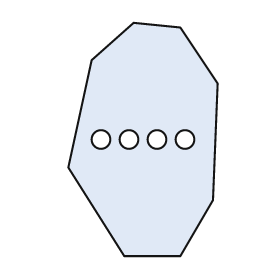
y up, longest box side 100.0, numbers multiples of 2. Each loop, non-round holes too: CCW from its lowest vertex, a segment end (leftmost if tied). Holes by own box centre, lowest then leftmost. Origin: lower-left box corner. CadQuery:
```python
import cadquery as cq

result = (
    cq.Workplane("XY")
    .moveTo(24.0, 0.0)
    .lineTo(48.0, 0.0)
    .lineTo(62.0, 24.0)
    .lineTo(64.0, 74.0)
    .lineTo(48.0, 98.0)
    .lineTo(28.0, 100.0)
    .lineTo(10.0, 84.0)
    .lineTo(0.0, 38.0)
    .close()
    .moveTo(14.0, 50.0)
    .circle(4.0)
    .moveTo(26.0, 50.0)
    .circle(4.0)
    .moveTo(38.0, 50.0)
    .circle(4.0)
    .moveTo(50.0, 50.0)
    .circle(4.0)
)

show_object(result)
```